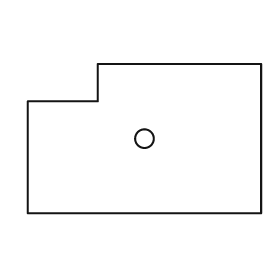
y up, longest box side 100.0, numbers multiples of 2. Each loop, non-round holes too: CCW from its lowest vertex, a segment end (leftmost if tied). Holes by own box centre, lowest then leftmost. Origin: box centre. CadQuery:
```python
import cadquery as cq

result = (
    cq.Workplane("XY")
    .moveTo(-50.0, -32.0)
    .lineTo(50.0, -32.0)
    .lineTo(50.0, 32.0)
    .lineTo(-20.0, 32.0)
    .lineTo(-20.0, 16.0)
    .lineTo(-50.0, 16.0)
    .close()
    .moveTo(0.0, 0.0)
    .circle(4.0)
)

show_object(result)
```